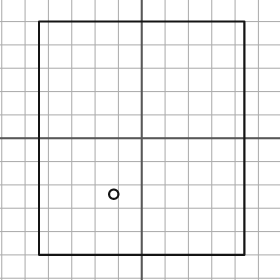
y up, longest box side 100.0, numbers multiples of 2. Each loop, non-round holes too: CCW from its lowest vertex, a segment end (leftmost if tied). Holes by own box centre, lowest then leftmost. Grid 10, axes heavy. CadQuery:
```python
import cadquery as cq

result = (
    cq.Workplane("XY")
    .moveTo(-44.0, -50.0)
    .lineTo(44.0, -50.0)
    .lineTo(44.0, 50.0)
    .lineTo(-44.0, 50.0)
    .close()
    .moveTo(-12.0, -24.0)
    .circle(2.0)
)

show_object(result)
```